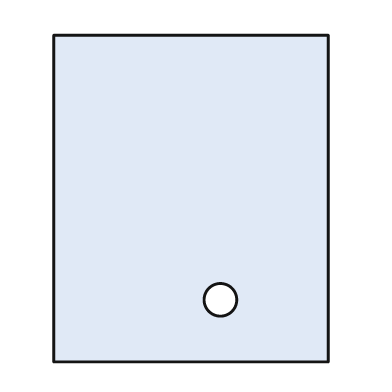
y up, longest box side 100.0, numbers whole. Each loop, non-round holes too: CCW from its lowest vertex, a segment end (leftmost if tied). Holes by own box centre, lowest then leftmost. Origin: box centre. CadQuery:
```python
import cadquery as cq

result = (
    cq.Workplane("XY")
    .moveTo(-42.0, -50.0)
    .lineTo(42.0, -50.0)
    .lineTo(42.0, 50.0)
    .lineTo(-42.0, 50.0)
    .close()
    .moveTo(9.0, -31.0)
    .circle(5.0)
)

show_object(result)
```